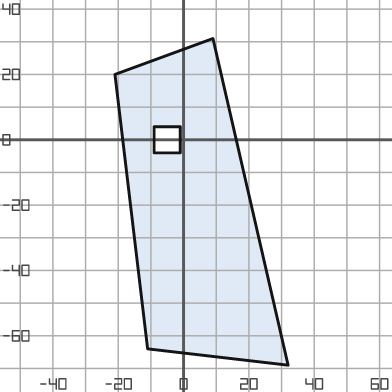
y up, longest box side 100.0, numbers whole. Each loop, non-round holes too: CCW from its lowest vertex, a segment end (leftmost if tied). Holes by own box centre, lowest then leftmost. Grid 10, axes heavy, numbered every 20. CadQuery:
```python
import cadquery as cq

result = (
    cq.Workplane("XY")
    .moveTo(32.0, -69.0)
    .lineTo(9.0, 31.0)
    .lineTo(-21.0, 20.0)
    .lineTo(-11.0, -64.0)
    .close()
    .moveTo(-9.0, -4.0)
    .lineTo(-1.0, -4.0)
    .lineTo(-1.0, 4.0)
    .lineTo(-9.0, 4.0)
    .close()
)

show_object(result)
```